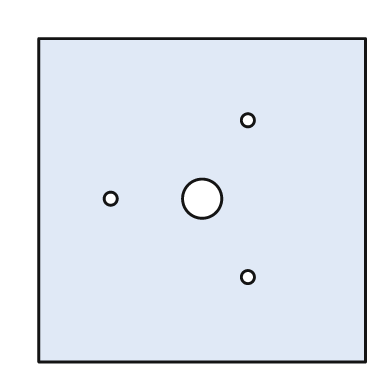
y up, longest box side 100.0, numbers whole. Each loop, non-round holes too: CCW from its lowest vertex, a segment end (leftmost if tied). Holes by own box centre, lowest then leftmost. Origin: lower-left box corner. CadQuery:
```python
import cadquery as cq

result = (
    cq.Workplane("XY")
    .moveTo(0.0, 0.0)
    .lineTo(100.0, 0.0)
    .lineTo(100.0, 99.0)
    .lineTo(0.0, 99.0)
    .close()
    .moveTo(64.0, 26.0)
    .circle(2.0)
    .moveTo(22.0, 50.0)
    .circle(2.0)
    .moveTo(50.0, 50.0)
    .circle(6.0)
    .moveTo(64.0, 74.0)
    .circle(2.0)
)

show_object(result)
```